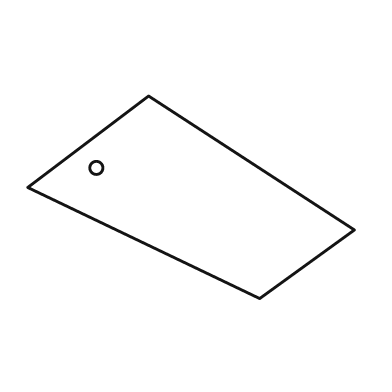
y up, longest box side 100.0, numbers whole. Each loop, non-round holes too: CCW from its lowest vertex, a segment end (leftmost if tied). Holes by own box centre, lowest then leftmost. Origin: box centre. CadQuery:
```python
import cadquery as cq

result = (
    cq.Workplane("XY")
    .moveTo(21.0, -31.0)
    .lineTo(50.0, -10.0)
    .lineTo(-13.0, 31.0)
    .lineTo(-50.0, 3.0)
    .close()
    .moveTo(-29.0, 9.0)
    .circle(2.0)
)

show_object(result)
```